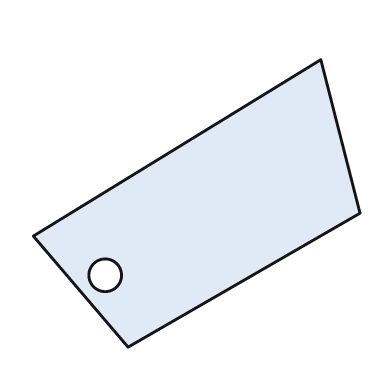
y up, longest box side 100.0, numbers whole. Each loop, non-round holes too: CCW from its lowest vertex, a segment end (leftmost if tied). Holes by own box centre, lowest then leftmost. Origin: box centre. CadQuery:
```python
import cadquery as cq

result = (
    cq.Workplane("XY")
    .moveTo(-21.0, -44.0)
    .lineTo(50.0, -3.0)
    .lineTo(38.0, 44.0)
    .lineTo(-50.0, -10.0)
    .close()
    .moveTo(-28.0, -22.0)
    .circle(5.0)
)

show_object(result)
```